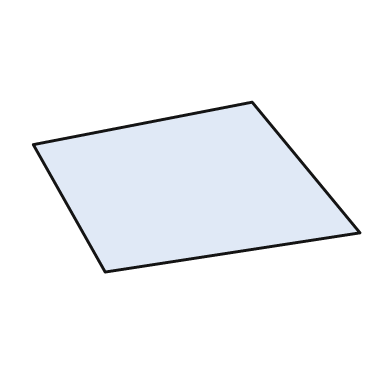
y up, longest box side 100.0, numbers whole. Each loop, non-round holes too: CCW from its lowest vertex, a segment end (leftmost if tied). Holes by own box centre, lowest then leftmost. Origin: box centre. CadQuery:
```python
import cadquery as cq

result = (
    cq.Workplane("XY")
    .moveTo(-28.0, -26.0)
    .lineTo(50.0, -14.0)
    .lineTo(17.0, 26.0)
    .lineTo(-50.0, 13.0)
    .close()
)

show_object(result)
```